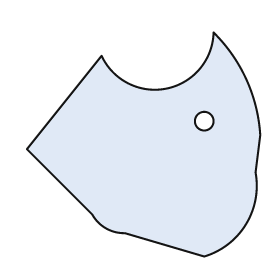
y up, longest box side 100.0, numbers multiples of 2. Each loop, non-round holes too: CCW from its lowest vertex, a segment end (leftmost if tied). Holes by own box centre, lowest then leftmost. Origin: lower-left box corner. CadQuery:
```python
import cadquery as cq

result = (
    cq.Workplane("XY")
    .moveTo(76.0, 0.0)
    .threePointArc((94.0, 14.0), (98.0, 36.0))
    .lineTo(100.0, 52.0)
    .threePointArc((94.0, 76.0), (80.0, 96.0))
    .threePointArc((60.0, 72.0), (32.0, 86.0))
    .lineTo(0.0, 46.0)
    .lineTo(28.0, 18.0)
    .threePointArc((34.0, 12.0), (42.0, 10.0))
    .close()
    .moveTo(76.0, 58.0)
    .circle(4.0)
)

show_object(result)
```